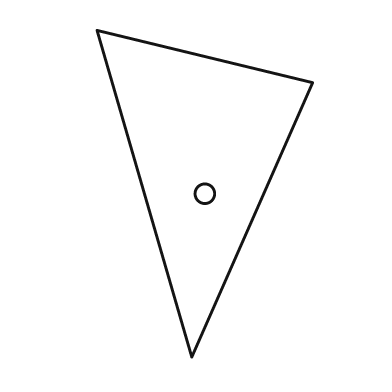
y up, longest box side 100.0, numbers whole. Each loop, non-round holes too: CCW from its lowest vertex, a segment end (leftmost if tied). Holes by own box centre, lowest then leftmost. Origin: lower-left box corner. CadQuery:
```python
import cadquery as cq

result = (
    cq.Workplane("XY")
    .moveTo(29.0, 0.0)
    .lineTo(66.0, 84.0)
    .lineTo(0.0, 100.0)
    .close()
    .moveTo(33.0, 50.0)
    .circle(3.0)
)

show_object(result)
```